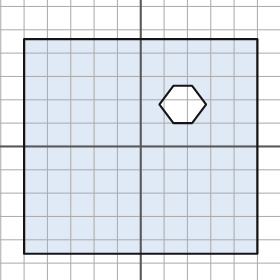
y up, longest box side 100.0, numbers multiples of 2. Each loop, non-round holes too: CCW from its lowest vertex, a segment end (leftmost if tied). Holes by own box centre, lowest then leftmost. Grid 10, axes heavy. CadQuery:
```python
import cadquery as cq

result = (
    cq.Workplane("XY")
    .moveTo(-50.0, -46.0)
    .lineTo(50.0, -46.0)
    .lineTo(50.0, 46.0)
    .lineTo(-50.0, 46.0)
    .close()
    .moveTo(14.0, 10.0)
    .lineTo(22.0, 10.0)
    .lineTo(28.0, 18.0)
    .lineTo(22.0, 26.0)
    .lineTo(14.0, 26.0)
    .lineTo(8.0, 18.0)
    .close()
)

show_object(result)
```